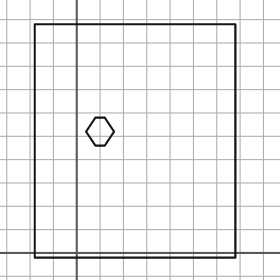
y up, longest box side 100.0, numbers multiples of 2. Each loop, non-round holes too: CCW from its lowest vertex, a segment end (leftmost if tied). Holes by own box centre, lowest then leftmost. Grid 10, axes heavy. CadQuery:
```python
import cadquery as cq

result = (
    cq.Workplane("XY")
    .moveTo(-18.0, -2.0)
    .lineTo(68.0, -2.0)
    .lineTo(68.0, 98.0)
    .lineTo(-18.0, 98.0)
    .close()
    .moveTo(8.0, 46.0)
    .lineTo(12.0, 46.0)
    .lineTo(16.0, 52.0)
    .lineTo(12.0, 58.0)
    .lineTo(8.0, 58.0)
    .lineTo(4.0, 52.0)
    .close()
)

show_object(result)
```